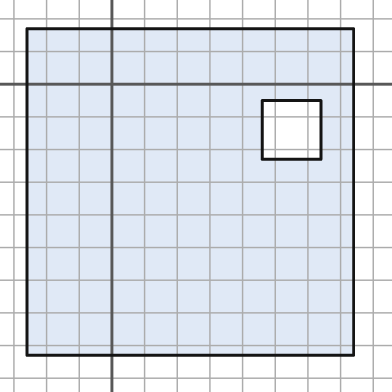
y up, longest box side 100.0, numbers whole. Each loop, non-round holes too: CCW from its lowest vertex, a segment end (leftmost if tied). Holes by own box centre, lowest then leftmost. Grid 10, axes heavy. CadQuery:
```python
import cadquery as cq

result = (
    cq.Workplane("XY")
    .moveTo(-26.0, -83.0)
    .lineTo(74.0, -83.0)
    .lineTo(74.0, 17.0)
    .lineTo(-26.0, 17.0)
    .close()
    .moveTo(46.0, -23.0)
    .lineTo(64.0, -23.0)
    .lineTo(64.0, -5.0)
    .lineTo(46.0, -5.0)
    .close()
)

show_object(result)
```